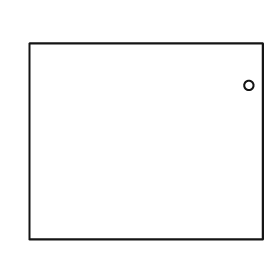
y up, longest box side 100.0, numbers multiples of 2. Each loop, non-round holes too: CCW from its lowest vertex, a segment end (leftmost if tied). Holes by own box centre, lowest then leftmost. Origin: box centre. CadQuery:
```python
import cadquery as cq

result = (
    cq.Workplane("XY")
    .moveTo(-50.0, -42.0)
    .lineTo(50.0, -42.0)
    .lineTo(50.0, 42.0)
    .lineTo(-50.0, 42.0)
    .close()
    .moveTo(44.0, 24.0)
    .circle(2.0)
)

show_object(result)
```